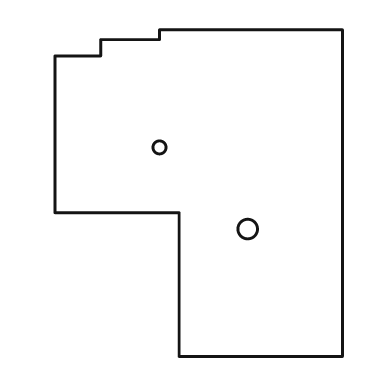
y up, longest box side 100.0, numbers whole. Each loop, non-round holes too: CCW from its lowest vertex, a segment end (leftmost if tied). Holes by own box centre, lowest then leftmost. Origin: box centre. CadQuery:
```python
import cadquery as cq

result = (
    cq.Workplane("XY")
    .moveTo(-6.0, -50.0)
    .lineTo(44.0, -50.0)
    .lineTo(44.0, 50.0)
    .lineTo(-12.0, 50.0)
    .lineTo(-12.0, 47.0)
    .lineTo(-30.0, 47.0)
    .lineTo(-30.0, 42.0)
    .lineTo(-44.0, 42.0)
    .lineTo(-44.0, -6.0)
    .lineTo(-6.0, -6.0)
    .close()
    .moveTo(15.0, -11.0)
    .circle(3.0)
    .moveTo(-12.0, 14.0)
    .circle(2.0)
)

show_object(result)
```